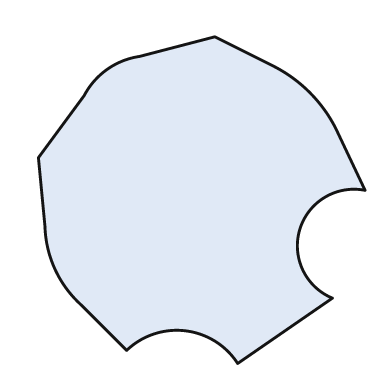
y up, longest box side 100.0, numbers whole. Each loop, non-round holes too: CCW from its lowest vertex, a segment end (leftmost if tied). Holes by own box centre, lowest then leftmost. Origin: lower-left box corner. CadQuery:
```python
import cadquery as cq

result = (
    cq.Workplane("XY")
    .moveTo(61.0, 0.0)
    .lineTo(90.0, 20.0)
    .threePointArc((80.0, 41.0), (100.0, 53.0))
    .lineTo(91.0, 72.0)
    .threePointArc((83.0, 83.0), (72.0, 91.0))
    .lineTo(54.0, 100.0)
    .lineTo(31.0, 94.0)
    .threePointArc((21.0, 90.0), (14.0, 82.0))
    .lineTo(0.0, 63.0)
    .lineTo(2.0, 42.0)
    .threePointArc((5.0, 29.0), (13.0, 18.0))
    .lineTo(27.0, 4.0)
    .threePointArc((45.0, 10.0), (61.0, 0.0))
    .close()
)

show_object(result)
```